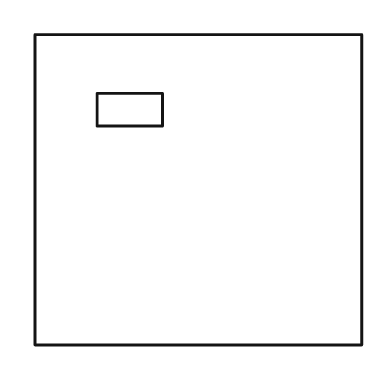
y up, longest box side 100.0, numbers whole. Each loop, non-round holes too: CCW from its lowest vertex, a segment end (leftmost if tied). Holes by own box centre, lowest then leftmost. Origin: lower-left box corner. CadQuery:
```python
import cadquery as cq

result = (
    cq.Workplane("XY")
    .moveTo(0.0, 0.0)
    .lineTo(100.0, 0.0)
    .lineTo(100.0, 95.0)
    .lineTo(0.0, 95.0)
    .close()
    .moveTo(19.0, 67.0)
    .lineTo(39.0, 67.0)
    .lineTo(39.0, 77.0)
    .lineTo(19.0, 77.0)
    .close()
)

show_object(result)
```